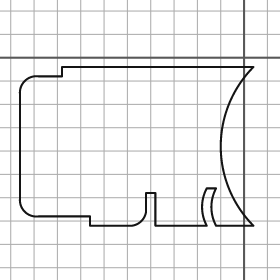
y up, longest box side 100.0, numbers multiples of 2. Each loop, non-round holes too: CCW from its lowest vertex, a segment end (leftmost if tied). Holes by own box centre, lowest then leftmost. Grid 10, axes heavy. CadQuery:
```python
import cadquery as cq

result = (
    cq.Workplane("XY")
    .moveTo(-66.0, -72.0)
    .lineTo(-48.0, -72.0)
    .threePointArc((-44.0, -70.0), (-42.0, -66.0))
    .lineTo(-42.0, -58.0)
    .lineTo(-38.0, -58.0)
    .lineTo(-38.0, -72.0)
    .lineTo(-16.0, -72.0)
    .threePointArc((-18.0, -64.0), (-16.0, -56.0))
    .lineTo(-12.0, -56.0)
    .threePointArc((-14.0, -64.0), (-12.0, -72.0))
    .lineTo(4.0, -72.0)
    .threePointArc((-10.0, -38.0), (4.0, -4.0))
    .lineTo(-78.0, -4.0)
    .lineTo(-78.0, -8.0)
    .lineTo(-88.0, -8.0)
    .threePointArc((-94.0, -10.0), (-96.0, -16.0))
    .lineTo(-96.0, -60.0)
    .threePointArc((-94.0, -66.0), (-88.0, -68.0))
    .lineTo(-66.0, -68.0)
    .close()
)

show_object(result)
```